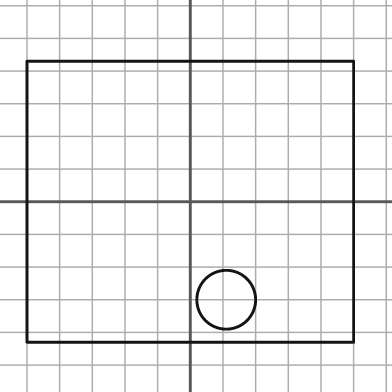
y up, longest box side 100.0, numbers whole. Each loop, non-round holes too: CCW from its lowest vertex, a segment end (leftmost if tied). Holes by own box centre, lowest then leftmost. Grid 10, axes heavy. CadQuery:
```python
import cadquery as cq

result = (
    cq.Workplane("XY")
    .moveTo(-50.0, -43.0)
    .lineTo(50.0, -43.0)
    .lineTo(50.0, 43.0)
    .lineTo(-50.0, 43.0)
    .close()
    .moveTo(11.0, -30.0)
    .circle(9.0)
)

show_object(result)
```